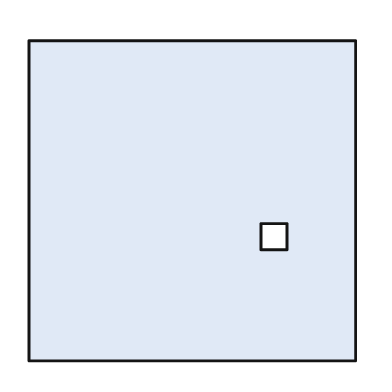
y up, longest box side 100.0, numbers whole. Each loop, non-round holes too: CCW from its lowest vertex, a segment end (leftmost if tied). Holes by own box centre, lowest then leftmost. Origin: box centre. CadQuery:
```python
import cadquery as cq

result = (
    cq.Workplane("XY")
    .moveTo(-50.0, -49.0)
    .lineTo(50.0, -49.0)
    .lineTo(50.0, 49.0)
    .lineTo(-50.0, 49.0)
    .close()
    .moveTo(21.0, -15.0)
    .lineTo(29.0, -15.0)
    .lineTo(29.0, -7.0)
    .lineTo(21.0, -7.0)
    .close()
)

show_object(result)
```